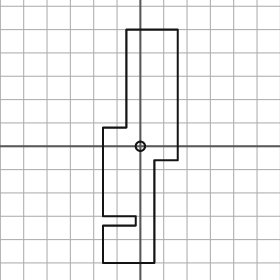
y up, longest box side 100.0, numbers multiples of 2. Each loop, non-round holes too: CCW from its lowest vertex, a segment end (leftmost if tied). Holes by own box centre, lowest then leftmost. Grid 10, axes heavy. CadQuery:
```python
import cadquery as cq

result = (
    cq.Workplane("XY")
    .moveTo(-16.0, -50.0)
    .lineTo(6.0, -50.0)
    .lineTo(6.0, -6.0)
    .lineTo(16.0, -6.0)
    .lineTo(16.0, 50.0)
    .lineTo(-6.0, 50.0)
    .lineTo(-6.0, 8.0)
    .lineTo(-16.0, 8.0)
    .lineTo(-16.0, -30.0)
    .lineTo(-2.0, -30.0)
    .lineTo(-2.0, -34.0)
    .lineTo(-16.0, -34.0)
    .close()
    .moveTo(0.0, 0.0)
    .circle(2.0)
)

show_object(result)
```